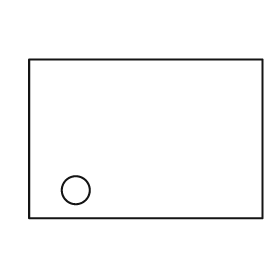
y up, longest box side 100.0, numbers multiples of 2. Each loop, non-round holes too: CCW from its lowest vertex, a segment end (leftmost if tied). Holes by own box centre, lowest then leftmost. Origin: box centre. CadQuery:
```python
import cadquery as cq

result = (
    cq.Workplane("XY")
    .moveTo(-50.0, -34.0)
    .lineTo(50.0, -34.0)
    .lineTo(50.0, 34.0)
    .lineTo(-50.0, 34.0)
    .close()
    .moveTo(-30.0, -22.0)
    .circle(6.0)
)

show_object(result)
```